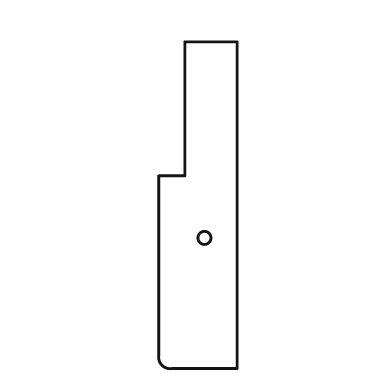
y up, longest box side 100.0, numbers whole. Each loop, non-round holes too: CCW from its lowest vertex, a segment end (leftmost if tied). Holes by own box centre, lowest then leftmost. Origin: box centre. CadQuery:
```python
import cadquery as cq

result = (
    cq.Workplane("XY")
    .moveTo(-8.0, -50.0)
    .lineTo(12.0, -50.0)
    .lineTo(12.0, 50.0)
    .lineTo(-4.0, 50.0)
    .lineTo(-4.0, 9.0)
    .lineTo(-12.0, 9.0)
    .lineTo(-12.0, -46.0)
    .threePointArc((-11.0, -49.0), (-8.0, -50.0))
    .close()
    .moveTo(2.0, -10.0)
    .circle(2.0)
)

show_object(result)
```